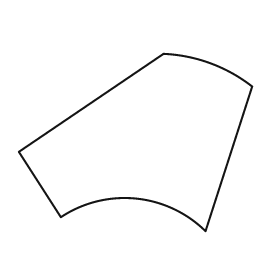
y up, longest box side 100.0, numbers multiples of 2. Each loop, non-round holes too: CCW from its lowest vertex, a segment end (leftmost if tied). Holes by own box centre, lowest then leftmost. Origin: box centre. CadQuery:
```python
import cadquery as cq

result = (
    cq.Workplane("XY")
    .moveTo(30.0, -38.0)
    .lineTo(50.0, 24.0)
    .threePointArc((32.0, 34.0), (12.0, 38.0))
    .lineTo(-50.0, -4.0)
    .lineTo(-32.0, -32.0)
    .threePointArc((0.0, -24.0), (30.0, -38.0))
    .close()
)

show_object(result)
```